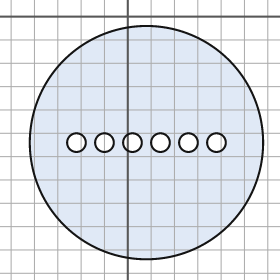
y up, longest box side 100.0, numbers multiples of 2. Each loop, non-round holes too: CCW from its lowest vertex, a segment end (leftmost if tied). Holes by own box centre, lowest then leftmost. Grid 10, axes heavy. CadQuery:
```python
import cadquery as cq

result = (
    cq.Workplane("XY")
    .moveTo(8.0, -54.0)
    .circle(50.0)
    .moveTo(-22.0, -54.0)
    .circle(4.0)
    .moveTo(-10.0, -54.0)
    .circle(4.0)
    .moveTo(2.0, -54.0)
    .circle(4.0)
    .moveTo(14.0, -54.0)
    .circle(4.0)
    .moveTo(26.0, -54.0)
    .circle(4.0)
    .moveTo(38.0, -54.0)
    .circle(4.0)
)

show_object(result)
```